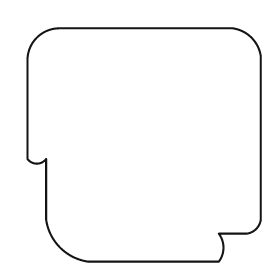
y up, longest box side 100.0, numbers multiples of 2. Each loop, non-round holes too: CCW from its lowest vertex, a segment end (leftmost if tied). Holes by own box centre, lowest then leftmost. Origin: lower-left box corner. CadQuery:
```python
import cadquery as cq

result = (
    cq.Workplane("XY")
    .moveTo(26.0, 0.0)
    .lineTo(82.0, 0.0)
    .threePointArc((84.0, 6.0), (82.0, 12.0))
    .lineTo(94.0, 12.0)
    .threePointArc((98.0, 14.0), (100.0, 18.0))
    .lineTo(100.0, 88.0)
    .threePointArc((96.0, 96.0), (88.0, 100.0))
    .lineTo(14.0, 100.0)
    .threePointArc((4.0, 96.0), (0.0, 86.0))
    .lineTo(0.0, 44.0)
    .threePointArc((4.0, 42.0), (8.0, 44.0))
    .lineTo(8.0, 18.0)
    .threePointArc((14.0, 6.0), (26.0, 0.0))
    .close()
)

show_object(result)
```